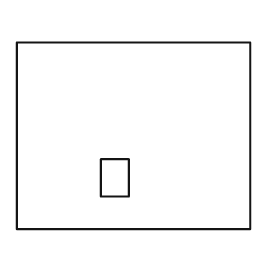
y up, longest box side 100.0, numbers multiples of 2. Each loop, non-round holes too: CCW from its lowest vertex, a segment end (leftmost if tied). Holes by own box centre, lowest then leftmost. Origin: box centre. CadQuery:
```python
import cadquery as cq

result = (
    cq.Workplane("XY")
    .moveTo(-50.0, -40.0)
    .lineTo(50.0, -40.0)
    .lineTo(50.0, 40.0)
    .lineTo(-50.0, 40.0)
    .close()
    .moveTo(-14.0, -26.0)
    .lineTo(-2.0, -26.0)
    .lineTo(-2.0, -10.0)
    .lineTo(-14.0, -10.0)
    .close()
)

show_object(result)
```